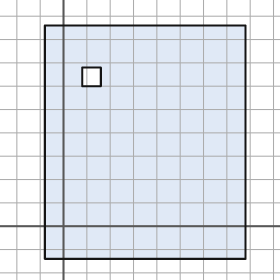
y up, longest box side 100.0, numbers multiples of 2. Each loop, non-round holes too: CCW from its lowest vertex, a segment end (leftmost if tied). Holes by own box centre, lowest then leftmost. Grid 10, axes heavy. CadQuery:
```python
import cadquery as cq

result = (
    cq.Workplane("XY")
    .moveTo(-8.0, -14.0)
    .lineTo(78.0, -14.0)
    .lineTo(78.0, 86.0)
    .lineTo(-8.0, 86.0)
    .close()
    .moveTo(8.0, 60.0)
    .lineTo(16.0, 60.0)
    .lineTo(16.0, 68.0)
    .lineTo(8.0, 68.0)
    .close()
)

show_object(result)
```